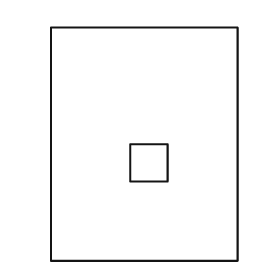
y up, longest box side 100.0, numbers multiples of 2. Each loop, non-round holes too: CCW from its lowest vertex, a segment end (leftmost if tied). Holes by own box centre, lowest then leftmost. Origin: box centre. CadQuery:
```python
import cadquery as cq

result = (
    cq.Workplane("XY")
    .moveTo(-40.0, -50.0)
    .lineTo(40.0, -50.0)
    .lineTo(40.0, 50.0)
    .lineTo(-40.0, 50.0)
    .close()
    .moveTo(-6.0, -16.0)
    .lineTo(10.0, -16.0)
    .lineTo(10.0, 0.0)
    .lineTo(-6.0, 0.0)
    .close()
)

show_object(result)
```